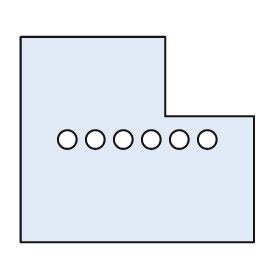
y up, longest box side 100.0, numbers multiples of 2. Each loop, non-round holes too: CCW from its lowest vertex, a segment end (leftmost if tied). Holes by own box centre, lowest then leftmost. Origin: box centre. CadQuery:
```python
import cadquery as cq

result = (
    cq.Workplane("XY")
    .moveTo(-50.0, -44.0)
    .lineTo(50.0, -44.0)
    .lineTo(50.0, 10.0)
    .lineTo(12.0, 10.0)
    .lineTo(12.0, 44.0)
    .lineTo(-50.0, 44.0)
    .close()
    .moveTo(-30.0, 0.0)
    .circle(4.0)
    .moveTo(-18.0, 0.0)
    .circle(4.0)
    .moveTo(-6.0, 0.0)
    .circle(4.0)
    .moveTo(6.0, 0.0)
    .circle(4.0)
    .moveTo(18.0, 0.0)
    .circle(4.0)
    .moveTo(30.0, 0.0)
    .circle(4.0)
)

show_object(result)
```